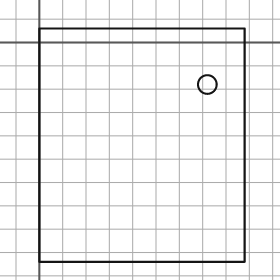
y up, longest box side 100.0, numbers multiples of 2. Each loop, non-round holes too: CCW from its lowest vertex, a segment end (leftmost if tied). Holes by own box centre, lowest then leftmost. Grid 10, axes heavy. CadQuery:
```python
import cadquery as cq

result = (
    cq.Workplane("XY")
    .moveTo(0.0, -94.0)
    .lineTo(88.0, -94.0)
    .lineTo(88.0, 6.0)
    .lineTo(0.0, 6.0)
    .close()
    .moveTo(72.0, -18.0)
    .circle(4.0)
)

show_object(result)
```